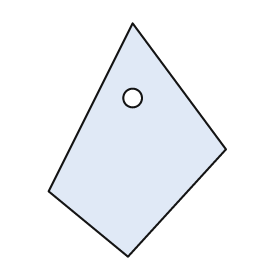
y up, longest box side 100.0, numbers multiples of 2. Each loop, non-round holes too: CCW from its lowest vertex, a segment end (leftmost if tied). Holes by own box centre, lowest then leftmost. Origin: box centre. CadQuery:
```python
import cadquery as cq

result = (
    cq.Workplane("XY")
    .moveTo(-4.0, -50.0)
    .lineTo(38.0, -4.0)
    .lineTo(-2.0, 50.0)
    .lineTo(-38.0, -22.0)
    .close()
    .moveTo(-2.0, 18.0)
    .circle(4.0)
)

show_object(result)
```